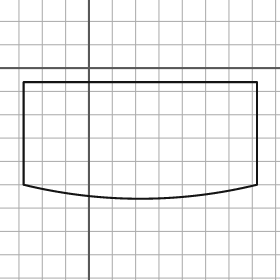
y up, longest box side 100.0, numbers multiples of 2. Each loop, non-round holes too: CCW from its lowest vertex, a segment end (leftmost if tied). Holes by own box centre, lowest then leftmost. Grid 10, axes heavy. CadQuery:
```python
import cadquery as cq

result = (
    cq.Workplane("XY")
    .moveTo(-28.0, -50.0)
    .threePointArc((22.0, -56.0), (72.0, -50.0))
    .lineTo(72.0, -6.0)
    .lineTo(-28.0, -6.0)
    .close()
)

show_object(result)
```